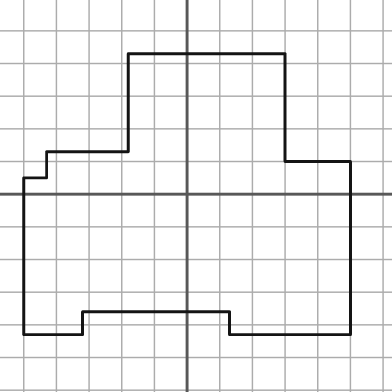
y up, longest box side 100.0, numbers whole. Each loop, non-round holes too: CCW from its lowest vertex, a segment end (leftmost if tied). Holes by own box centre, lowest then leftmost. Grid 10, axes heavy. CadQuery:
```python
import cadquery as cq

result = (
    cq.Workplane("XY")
    .moveTo(-50.0, -43.0)
    .lineTo(-32.0, -43.0)
    .lineTo(-32.0, -36.0)
    .lineTo(13.0, -36.0)
    .lineTo(13.0, -43.0)
    .lineTo(50.0, -43.0)
    .lineTo(50.0, 10.0)
    .lineTo(30.0, 10.0)
    .lineTo(30.0, 43.0)
    .lineTo(-18.0, 43.0)
    .lineTo(-18.0, 13.0)
    .lineTo(-43.0, 13.0)
    .lineTo(-43.0, 5.0)
    .lineTo(-50.0, 5.0)
    .close()
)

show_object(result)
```